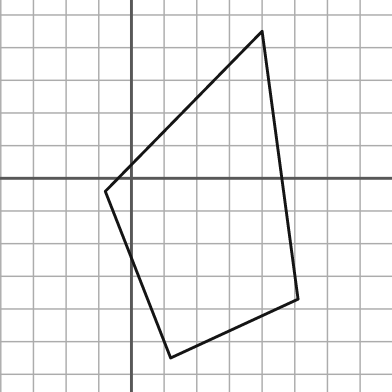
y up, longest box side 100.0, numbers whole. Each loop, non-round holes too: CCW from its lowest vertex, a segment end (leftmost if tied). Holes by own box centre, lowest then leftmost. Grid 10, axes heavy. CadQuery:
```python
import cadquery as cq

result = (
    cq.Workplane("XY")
    .moveTo(12.0, -55.0)
    .lineTo(51.0, -37.0)
    .lineTo(40.0, 45.0)
    .lineTo(-8.0, -4.0)
    .close()
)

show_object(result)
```